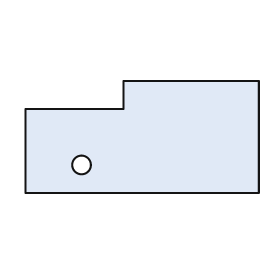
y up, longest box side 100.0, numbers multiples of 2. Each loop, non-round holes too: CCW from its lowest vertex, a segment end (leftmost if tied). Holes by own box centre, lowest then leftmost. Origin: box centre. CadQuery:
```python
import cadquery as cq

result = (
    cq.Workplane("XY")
    .moveTo(-50.0, -24.0)
    .lineTo(50.0, -24.0)
    .lineTo(50.0, 24.0)
    .lineTo(-8.0, 24.0)
    .lineTo(-8.0, 12.0)
    .lineTo(-50.0, 12.0)
    .close()
    .moveTo(-26.0, -12.0)
    .circle(4.0)
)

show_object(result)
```